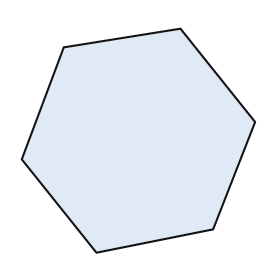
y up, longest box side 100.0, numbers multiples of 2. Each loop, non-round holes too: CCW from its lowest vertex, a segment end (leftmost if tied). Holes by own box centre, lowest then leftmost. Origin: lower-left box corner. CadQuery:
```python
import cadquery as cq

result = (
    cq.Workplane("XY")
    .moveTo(32.0, 0.0)
    .lineTo(82.0, 10.0)
    .lineTo(100.0, 56.0)
    .lineTo(68.0, 96.0)
    .lineTo(18.0, 88.0)
    .lineTo(0.0, 40.0)
    .close()
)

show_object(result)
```